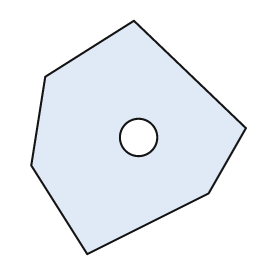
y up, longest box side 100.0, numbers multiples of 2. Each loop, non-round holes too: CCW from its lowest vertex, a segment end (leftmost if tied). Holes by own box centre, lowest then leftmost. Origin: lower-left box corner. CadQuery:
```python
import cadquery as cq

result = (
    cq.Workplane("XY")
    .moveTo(24.0, 0.0)
    .lineTo(76.0, 26.0)
    .lineTo(92.0, 54.0)
    .lineTo(44.0, 100.0)
    .lineTo(6.0, 76.0)
    .lineTo(0.0, 38.0)
    .close()
    .moveTo(46.0, 50.0)
    .circle(8.0)
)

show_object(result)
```